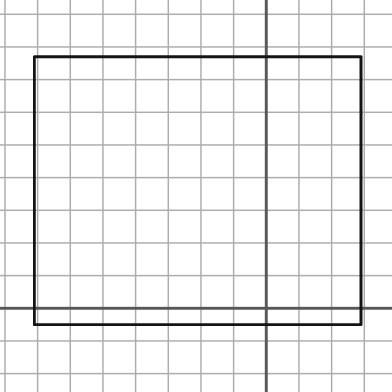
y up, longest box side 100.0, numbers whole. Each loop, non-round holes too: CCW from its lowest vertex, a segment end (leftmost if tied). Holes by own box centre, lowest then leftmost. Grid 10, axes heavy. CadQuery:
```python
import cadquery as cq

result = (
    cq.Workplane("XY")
    .moveTo(-71.0, -5.0)
    .lineTo(29.0, -5.0)
    .lineTo(29.0, 77.0)
    .lineTo(-71.0, 77.0)
    .close()
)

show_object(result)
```